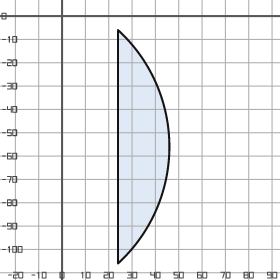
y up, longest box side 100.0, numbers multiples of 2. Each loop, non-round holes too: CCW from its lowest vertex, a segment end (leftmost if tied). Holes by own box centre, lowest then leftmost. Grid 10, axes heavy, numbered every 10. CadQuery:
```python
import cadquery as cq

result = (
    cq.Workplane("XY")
    .moveTo(24.0, -106.0)
    .threePointArc((46.0, -56.0), (24.0, -6.0))
    .close()
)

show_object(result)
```